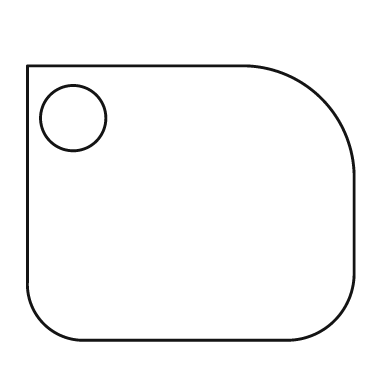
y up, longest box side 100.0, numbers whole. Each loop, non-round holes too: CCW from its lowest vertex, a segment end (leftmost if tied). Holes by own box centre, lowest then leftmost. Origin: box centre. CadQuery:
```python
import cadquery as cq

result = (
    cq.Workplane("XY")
    .moveTo(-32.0, -42.0)
    .lineTo(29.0, -42.0)
    .threePointArc((44.0, -36.0), (50.0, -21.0))
    .lineTo(50.0, 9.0)
    .threePointArc((40.0, 32.0), (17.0, 42.0))
    .lineTo(-50.0, 42.0)
    .lineTo(-50.0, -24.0)
    .threePointArc((-45.0, -37.0), (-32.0, -42.0))
    .close()
    .moveTo(-36.0, 26.0)
    .circle(10.0)
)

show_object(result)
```